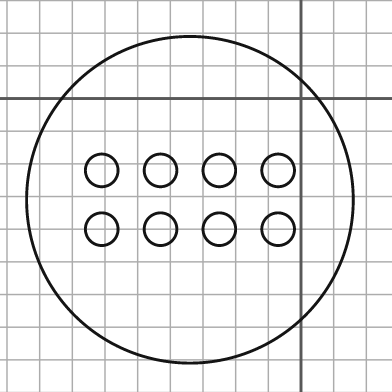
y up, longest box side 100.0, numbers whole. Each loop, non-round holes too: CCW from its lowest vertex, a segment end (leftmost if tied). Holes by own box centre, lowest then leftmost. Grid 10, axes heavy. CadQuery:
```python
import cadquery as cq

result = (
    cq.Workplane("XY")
    .moveTo(-34.0, -31.0)
    .circle(50.0)
    .moveTo(-61.0, -40.0)
    .circle(5.0)
    .moveTo(-43.0, -40.0)
    .circle(5.0)
    .moveTo(-25.0, -40.0)
    .circle(5.0)
    .moveTo(-7.0, -40.0)
    .circle(5.0)
    .moveTo(-61.0, -22.0)
    .circle(5.0)
    .moveTo(-43.0, -22.0)
    .circle(5.0)
    .moveTo(-25.0, -22.0)
    .circle(5.0)
    .moveTo(-7.0, -22.0)
    .circle(5.0)
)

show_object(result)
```